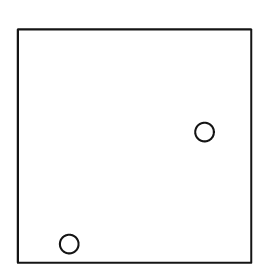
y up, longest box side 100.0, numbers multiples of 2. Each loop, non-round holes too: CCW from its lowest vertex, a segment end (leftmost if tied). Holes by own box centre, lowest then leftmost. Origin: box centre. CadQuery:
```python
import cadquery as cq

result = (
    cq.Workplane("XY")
    .moveTo(-50.0, -50.0)
    .lineTo(50.0, -50.0)
    .lineTo(50.0, 50.0)
    .lineTo(-50.0, 50.0)
    .close()
    .moveTo(-28.0, -42.0)
    .circle(4.0)
    .moveTo(30.0, 6.0)
    .circle(4.0)
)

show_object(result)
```